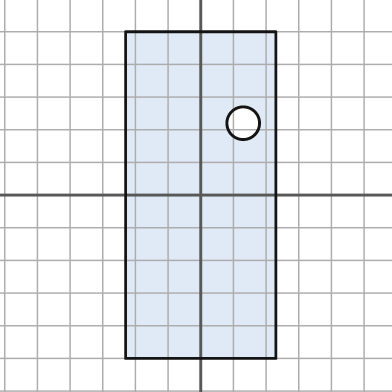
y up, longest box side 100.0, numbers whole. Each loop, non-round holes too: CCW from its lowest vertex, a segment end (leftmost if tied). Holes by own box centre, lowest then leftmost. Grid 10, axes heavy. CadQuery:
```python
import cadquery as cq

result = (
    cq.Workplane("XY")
    .moveTo(-23.0, -50.0)
    .lineTo(23.0, -50.0)
    .lineTo(23.0, 50.0)
    .lineTo(-23.0, 50.0)
    .close()
    .moveTo(13.0, 22.0)
    .circle(5.0)
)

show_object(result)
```